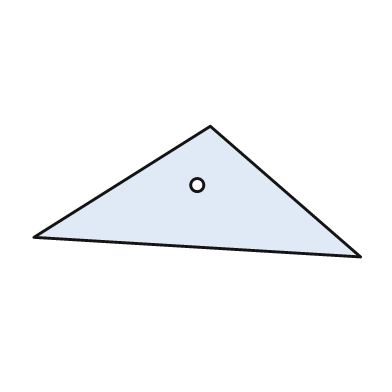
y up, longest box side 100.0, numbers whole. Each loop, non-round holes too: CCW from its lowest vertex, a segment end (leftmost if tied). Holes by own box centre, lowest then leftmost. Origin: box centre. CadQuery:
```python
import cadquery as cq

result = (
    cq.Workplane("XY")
    .moveTo(50.0, -20.0)
    .lineTo(4.0, 20.0)
    .lineTo(-50.0, -14.0)
    .close()
    .moveTo(0.0, 2.0)
    .circle(2.0)
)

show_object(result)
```